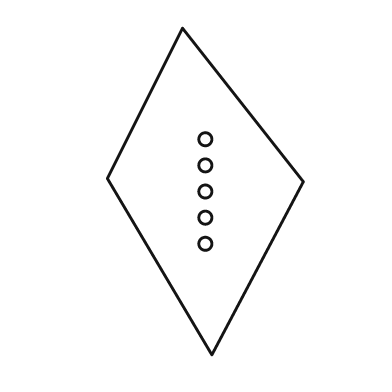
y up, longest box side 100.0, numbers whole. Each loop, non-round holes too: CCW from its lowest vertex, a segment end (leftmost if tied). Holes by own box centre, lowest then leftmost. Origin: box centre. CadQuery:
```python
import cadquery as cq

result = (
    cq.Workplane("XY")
    .moveTo(2.0, -50.0)
    .lineTo(30.0, 3.0)
    .lineTo(-7.0, 50.0)
    .lineTo(-30.0, 4.0)
    .close()
    .moveTo(0.0, -16.0)
    .circle(2.0)
    .moveTo(0.0, -8.0)
    .circle(2.0)
    .moveTo(0.0, 0.0)
    .circle(2.0)
    .moveTo(0.0, 8.0)
    .circle(2.0)
    .moveTo(0.0, 16.0)
    .circle(2.0)
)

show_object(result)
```